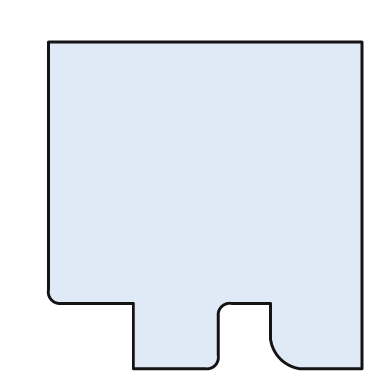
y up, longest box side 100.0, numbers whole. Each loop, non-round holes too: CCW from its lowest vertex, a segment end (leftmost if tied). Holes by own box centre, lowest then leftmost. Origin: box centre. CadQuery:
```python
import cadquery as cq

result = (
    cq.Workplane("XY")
    .moveTo(-22.0, -50.0)
    .lineTo(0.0, -50.0)
    .threePointArc((3.0, -49.0), (4.0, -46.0))
    .lineTo(4.0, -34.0)
    .threePointArc((5.0, -31.0), (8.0, -30.0))
    .lineTo(20.0, -30.0)
    .lineTo(20.0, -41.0)
    .threePointArc((23.0, -47.0), (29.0, -50.0))
    .lineTo(48.0, -50.0)
    .lineTo(48.0, 50.0)
    .lineTo(-48.0, 50.0)
    .lineTo(-48.0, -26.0)
    .threePointArc((-47.0, -29.0), (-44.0, -30.0))
    .lineTo(-22.0, -30.0)
    .close()
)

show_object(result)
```